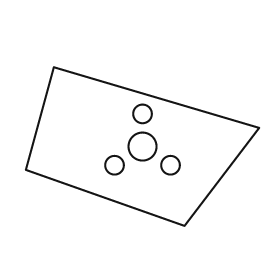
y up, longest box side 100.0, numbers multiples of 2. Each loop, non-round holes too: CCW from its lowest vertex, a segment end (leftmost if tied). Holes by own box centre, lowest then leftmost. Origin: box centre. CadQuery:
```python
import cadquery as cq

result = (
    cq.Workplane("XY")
    .moveTo(18.0, -34.0)
    .lineTo(50.0, 8.0)
    .lineTo(-38.0, 34.0)
    .lineTo(-50.0, -10.0)
    .close()
    .moveTo(-12.0, -8.0)
    .circle(4.0)
    .moveTo(12.0, -8.0)
    .circle(4.0)
    .moveTo(0.0, 0.0)
    .circle(6.0)
    .moveTo(0.0, 14.0)
    .circle(4.0)
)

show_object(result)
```